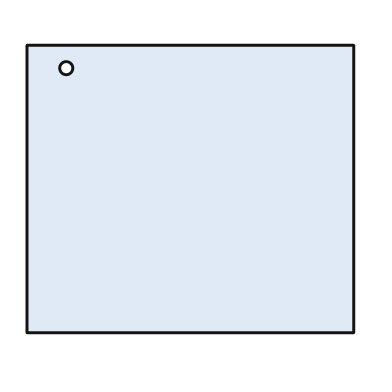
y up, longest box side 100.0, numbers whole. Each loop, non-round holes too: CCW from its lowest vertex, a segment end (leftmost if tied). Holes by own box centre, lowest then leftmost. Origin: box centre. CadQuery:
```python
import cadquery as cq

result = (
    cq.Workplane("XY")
    .moveTo(-50.0, -44.0)
    .lineTo(50.0, -44.0)
    .lineTo(50.0, 44.0)
    .lineTo(-50.0, 44.0)
    .close()
    .moveTo(-38.0, 37.0)
    .circle(2.0)
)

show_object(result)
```